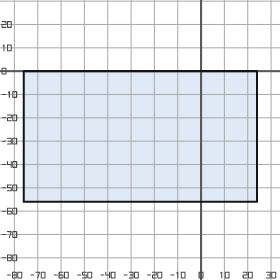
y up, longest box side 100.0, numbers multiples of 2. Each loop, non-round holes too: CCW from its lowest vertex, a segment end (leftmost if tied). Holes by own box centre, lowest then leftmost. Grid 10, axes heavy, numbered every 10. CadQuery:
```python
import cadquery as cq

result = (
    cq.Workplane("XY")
    .moveTo(-76.0, -56.0)
    .lineTo(24.0, -56.0)
    .lineTo(24.0, 0.0)
    .lineTo(-76.0, 0.0)
    .close()
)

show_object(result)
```